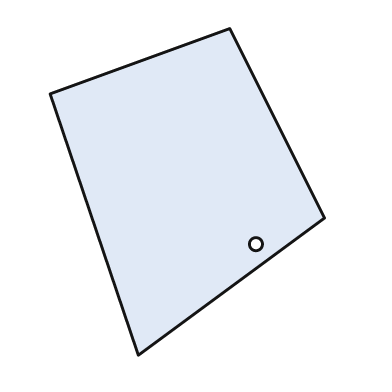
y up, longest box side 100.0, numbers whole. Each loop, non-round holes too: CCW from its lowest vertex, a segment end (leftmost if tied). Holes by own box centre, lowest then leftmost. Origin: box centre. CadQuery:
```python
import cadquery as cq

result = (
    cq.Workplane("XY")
    .moveTo(-15.0, -50.0)
    .lineTo(42.0, -8.0)
    .lineTo(13.0, 50.0)
    .lineTo(-42.0, 30.0)
    .close()
    .moveTo(21.0, -16.0)
    .circle(2.0)
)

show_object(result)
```